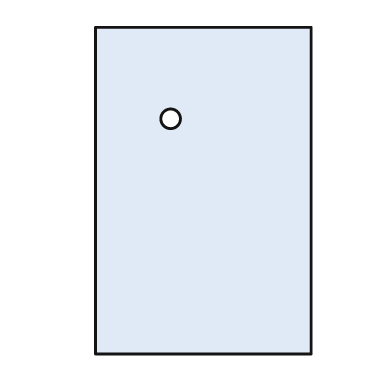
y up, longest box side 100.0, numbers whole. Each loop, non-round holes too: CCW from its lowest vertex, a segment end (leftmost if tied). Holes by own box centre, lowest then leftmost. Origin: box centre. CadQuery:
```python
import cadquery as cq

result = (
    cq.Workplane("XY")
    .moveTo(-33.0, -50.0)
    .lineTo(33.0, -50.0)
    .lineTo(33.0, 50.0)
    .lineTo(-33.0, 50.0)
    .close()
    .moveTo(-10.0, 22.0)
    .circle(3.0)
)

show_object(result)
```